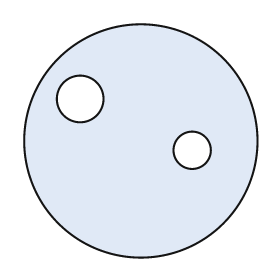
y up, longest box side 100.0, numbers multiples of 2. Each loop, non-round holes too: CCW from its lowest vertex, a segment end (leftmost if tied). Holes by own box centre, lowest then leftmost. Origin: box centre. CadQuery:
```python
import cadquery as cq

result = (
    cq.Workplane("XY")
    .moveTo(0.0, 0.0)
    .circle(50.0)
    .moveTo(22.0, -4.0)
    .circle(8.0)
    .moveTo(-26.0, 18.0)
    .circle(10.0)
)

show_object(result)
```